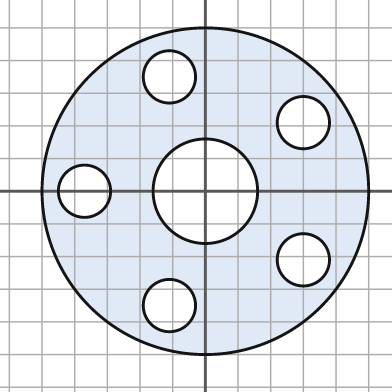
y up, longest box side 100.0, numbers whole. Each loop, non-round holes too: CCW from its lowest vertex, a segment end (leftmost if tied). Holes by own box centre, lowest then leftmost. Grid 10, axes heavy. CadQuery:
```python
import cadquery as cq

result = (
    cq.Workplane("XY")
    .moveTo(0.0, 0.0)
    .circle(50.0)
    .moveTo(-11.0, -35.0)
    .circle(8.0)
    .moveTo(30.0, -21.0)
    .circle(8.0)
    .moveTo(-37.0, 0.0)
    .circle(8.0)
    .moveTo(0.0, 0.0)
    .circle(16.0)
    .moveTo(30.0, 21.0)
    .circle(8.0)
    .moveTo(-11.0, 35.0)
    .circle(8.0)
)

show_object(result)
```